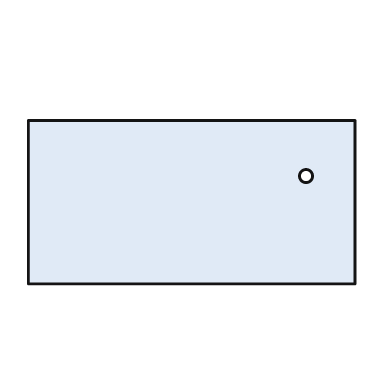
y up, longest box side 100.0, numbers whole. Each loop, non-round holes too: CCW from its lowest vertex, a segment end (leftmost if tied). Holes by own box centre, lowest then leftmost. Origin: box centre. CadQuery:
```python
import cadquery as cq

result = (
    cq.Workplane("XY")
    .moveTo(-50.0, -25.0)
    .lineTo(50.0, -25.0)
    .lineTo(50.0, 25.0)
    .lineTo(-50.0, 25.0)
    .close()
    .moveTo(35.0, 8.0)
    .circle(2.0)
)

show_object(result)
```